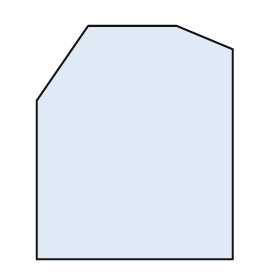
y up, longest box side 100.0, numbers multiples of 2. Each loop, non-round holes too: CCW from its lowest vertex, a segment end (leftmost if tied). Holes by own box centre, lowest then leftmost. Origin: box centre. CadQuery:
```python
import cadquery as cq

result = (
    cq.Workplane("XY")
    .moveTo(-42.0, -50.0)
    .lineTo(42.0, -50.0)
    .lineTo(42.0, 40.0)
    .lineTo(18.0, 50.0)
    .lineTo(-20.0, 50.0)
    .lineTo(-42.0, 18.0)
    .close()
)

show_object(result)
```